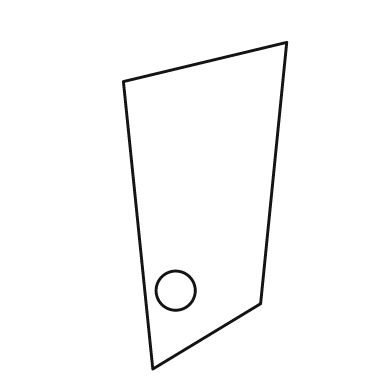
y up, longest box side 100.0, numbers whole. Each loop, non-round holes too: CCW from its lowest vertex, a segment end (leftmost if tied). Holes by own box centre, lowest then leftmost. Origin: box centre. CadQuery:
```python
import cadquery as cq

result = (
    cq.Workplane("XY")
    .moveTo(-16.0, -50.0)
    .lineTo(17.0, -30.0)
    .lineTo(25.0, 50.0)
    .lineTo(-25.0, 38.0)
    .close()
    .moveTo(-9.0, -26.0)
    .circle(6.0)
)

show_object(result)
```